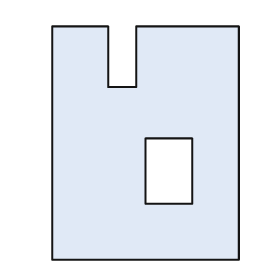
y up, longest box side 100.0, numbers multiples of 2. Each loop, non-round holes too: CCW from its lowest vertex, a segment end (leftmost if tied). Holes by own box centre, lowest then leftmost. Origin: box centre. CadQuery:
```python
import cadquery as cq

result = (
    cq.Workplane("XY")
    .moveTo(-40.0, -50.0)
    .lineTo(40.0, -50.0)
    .lineTo(40.0, 50.0)
    .lineTo(-4.0, 50.0)
    .lineTo(-4.0, 24.0)
    .lineTo(-16.0, 24.0)
    .lineTo(-16.0, 50.0)
    .lineTo(-40.0, 50.0)
    .close()
    .moveTo(0.0, -26.0)
    .lineTo(20.0, -26.0)
    .lineTo(20.0, 2.0)
    .lineTo(0.0, 2.0)
    .close()
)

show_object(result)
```